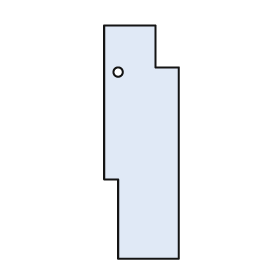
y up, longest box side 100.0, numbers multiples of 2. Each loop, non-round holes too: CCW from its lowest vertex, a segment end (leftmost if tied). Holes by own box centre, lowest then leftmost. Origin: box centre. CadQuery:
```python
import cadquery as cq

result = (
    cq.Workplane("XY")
    .moveTo(-10.0, -50.0)
    .lineTo(16.0, -50.0)
    .lineTo(16.0, 32.0)
    .lineTo(6.0, 32.0)
    .lineTo(6.0, 50.0)
    .lineTo(-16.0, 50.0)
    .lineTo(-16.0, -16.0)
    .lineTo(-10.0, -16.0)
    .close()
    .moveTo(-10.0, 30.0)
    .circle(2.0)
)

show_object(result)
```